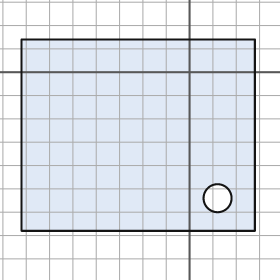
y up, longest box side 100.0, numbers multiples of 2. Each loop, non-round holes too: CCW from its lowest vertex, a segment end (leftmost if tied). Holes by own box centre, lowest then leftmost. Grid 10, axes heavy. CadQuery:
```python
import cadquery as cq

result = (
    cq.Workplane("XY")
    .moveTo(-72.0, -68.0)
    .lineTo(28.0, -68.0)
    .lineTo(28.0, 14.0)
    .lineTo(-72.0, 14.0)
    .close()
    .moveTo(12.0, -54.0)
    .circle(6.0)
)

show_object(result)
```